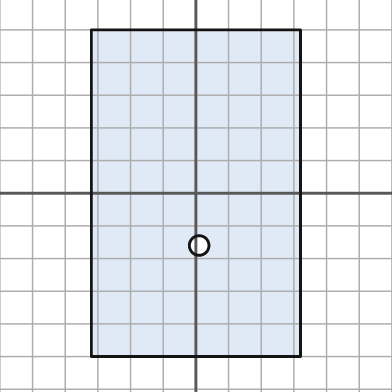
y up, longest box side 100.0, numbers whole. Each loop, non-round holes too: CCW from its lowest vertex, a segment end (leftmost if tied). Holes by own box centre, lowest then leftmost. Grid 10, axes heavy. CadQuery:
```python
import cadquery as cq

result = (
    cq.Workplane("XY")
    .moveTo(-32.0, -50.0)
    .lineTo(32.0, -50.0)
    .lineTo(32.0, 50.0)
    .lineTo(-32.0, 50.0)
    .close()
    .moveTo(1.0, -16.0)
    .circle(3.0)
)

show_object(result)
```